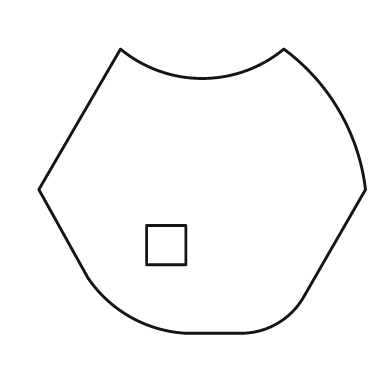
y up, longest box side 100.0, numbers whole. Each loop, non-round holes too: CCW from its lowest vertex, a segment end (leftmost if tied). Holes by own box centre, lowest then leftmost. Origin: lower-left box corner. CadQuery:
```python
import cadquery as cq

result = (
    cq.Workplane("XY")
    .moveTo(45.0, 0.0)
    .lineTo(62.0, 0.0)
    .threePointArc((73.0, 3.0), (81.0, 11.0))
    .lineTo(100.0, 44.0)
    .threePointArc((92.0, 68.0), (75.0, 87.0))
    .threePointArc((50.0, 78.0), (25.0, 87.0))
    .lineTo(0.0, 44.0)
    .lineTo(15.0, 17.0)
    .threePointArc((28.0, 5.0), (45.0, 0.0))
    .close()
    .moveTo(33.0, 21.0)
    .lineTo(45.0, 21.0)
    .lineTo(45.0, 33.0)
    .lineTo(33.0, 33.0)
    .close()
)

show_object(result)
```